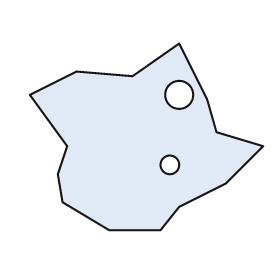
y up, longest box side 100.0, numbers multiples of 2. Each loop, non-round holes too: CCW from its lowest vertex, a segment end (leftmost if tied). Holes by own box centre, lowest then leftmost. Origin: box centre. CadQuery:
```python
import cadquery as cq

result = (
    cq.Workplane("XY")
    .moveTo(-16.0, -40.0)
    .lineTo(6.0, -40.0)
    .lineTo(14.0, -30.0)
    .lineTo(34.0, -20.0)
    .lineTo(50.0, -4.0)
    .lineTo(30.0, 2.0)
    .lineTo(26.0, 16.0)
    .lineTo(14.0, 40.0)
    .lineTo(-6.0, 26.0)
    .lineTo(-30.0, 28.0)
    .lineTo(-50.0, 18.0)
    .lineTo(-34.0, -4.0)
    .lineTo(-38.0, -16.0)
    .lineTo(-36.0, -28.0)
    .close()
    .moveTo(10.0, -12.0)
    .circle(4.0)
    .moveTo(14.0, 18.0)
    .circle(6.0)
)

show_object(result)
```